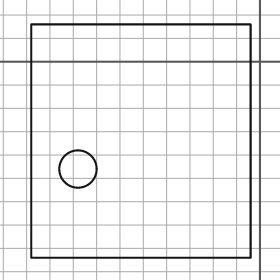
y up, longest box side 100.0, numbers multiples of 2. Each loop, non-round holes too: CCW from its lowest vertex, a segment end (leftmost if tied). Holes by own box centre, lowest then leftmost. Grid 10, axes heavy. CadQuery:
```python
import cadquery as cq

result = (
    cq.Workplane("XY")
    .moveTo(-98.0, -84.0)
    .lineTo(-4.0, -84.0)
    .lineTo(-4.0, 16.0)
    .lineTo(-98.0, 16.0)
    .close()
    .moveTo(-78.0, -46.0)
    .circle(8.0)
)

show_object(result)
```